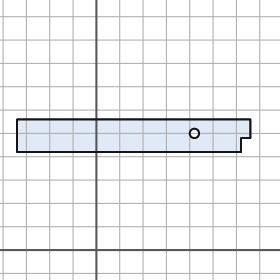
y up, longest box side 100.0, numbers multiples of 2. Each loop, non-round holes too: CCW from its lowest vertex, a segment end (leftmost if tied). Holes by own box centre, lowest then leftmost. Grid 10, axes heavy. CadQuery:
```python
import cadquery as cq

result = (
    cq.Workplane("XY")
    .moveTo(-34.0, 42.0)
    .lineTo(62.0, 42.0)
    .lineTo(62.0, 48.0)
    .lineTo(66.0, 48.0)
    .lineTo(66.0, 56.0)
    .lineTo(-34.0, 56.0)
    .close()
    .moveTo(42.0, 50.0)
    .circle(2.0)
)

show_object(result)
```